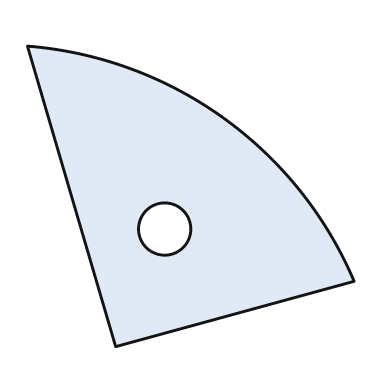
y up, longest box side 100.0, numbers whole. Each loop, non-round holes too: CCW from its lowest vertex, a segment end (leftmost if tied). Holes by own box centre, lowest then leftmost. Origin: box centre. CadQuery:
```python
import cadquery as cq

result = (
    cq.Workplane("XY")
    .moveTo(-23.0, -46.0)
    .lineTo(50.0, -26.0)
    .threePointArc((10.0, 24.0), (-50.0, 46.0))
    .close()
    .moveTo(-8.0, -10.0)
    .circle(8.0)
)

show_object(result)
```